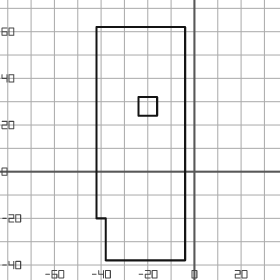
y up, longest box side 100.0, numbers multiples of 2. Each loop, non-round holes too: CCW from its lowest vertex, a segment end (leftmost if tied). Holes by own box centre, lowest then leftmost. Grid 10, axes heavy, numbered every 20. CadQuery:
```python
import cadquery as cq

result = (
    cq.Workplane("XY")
    .moveTo(-38.0, -38.0)
    .lineTo(-4.0, -38.0)
    .lineTo(-4.0, 62.0)
    .lineTo(-42.0, 62.0)
    .lineTo(-42.0, -20.0)
    .lineTo(-38.0, -20.0)
    .close()
    .moveTo(-24.0, 24.0)
    .lineTo(-16.0, 24.0)
    .lineTo(-16.0, 32.0)
    .lineTo(-24.0, 32.0)
    .close()
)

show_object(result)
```